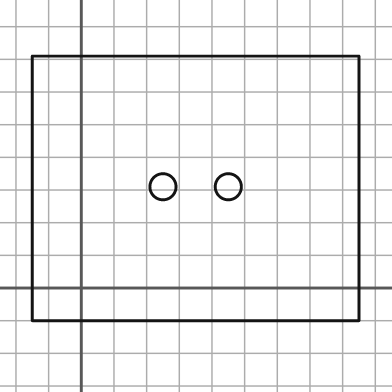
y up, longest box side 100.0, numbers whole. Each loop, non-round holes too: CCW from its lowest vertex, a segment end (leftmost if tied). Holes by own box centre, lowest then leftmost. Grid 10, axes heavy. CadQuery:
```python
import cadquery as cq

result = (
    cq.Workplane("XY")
    .moveTo(-15.0, -10.0)
    .lineTo(85.0, -10.0)
    .lineTo(85.0, 71.0)
    .lineTo(-15.0, 71.0)
    .close()
    .moveTo(25.0, 31.0)
    .circle(4.0)
    .moveTo(45.0, 31.0)
    .circle(4.0)
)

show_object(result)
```